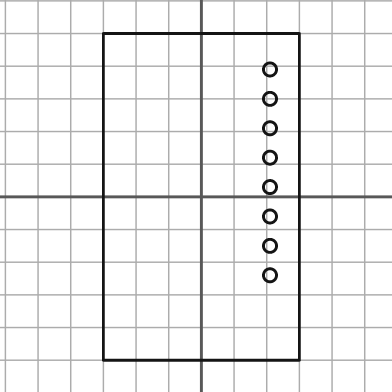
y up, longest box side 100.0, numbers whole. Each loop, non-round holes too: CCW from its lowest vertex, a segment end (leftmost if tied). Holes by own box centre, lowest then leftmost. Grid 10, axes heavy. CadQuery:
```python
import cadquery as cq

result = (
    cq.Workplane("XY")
    .moveTo(-30.0, -50.0)
    .lineTo(30.0, -50.0)
    .lineTo(30.0, 50.0)
    .lineTo(-30.0, 50.0)
    .close()
    .moveTo(21.0, -24.0)
    .circle(2.0)
    .moveTo(21.0, -15.0)
    .circle(2.0)
    .moveTo(21.0, -6.0)
    .circle(2.0)
    .moveTo(21.0, 3.0)
    .circle(2.0)
    .moveTo(21.0, 12.0)
    .circle(2.0)
    .moveTo(21.0, 21.0)
    .circle(2.0)
    .moveTo(21.0, 30.0)
    .circle(2.0)
    .moveTo(21.0, 39.0)
    .circle(2.0)
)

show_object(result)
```